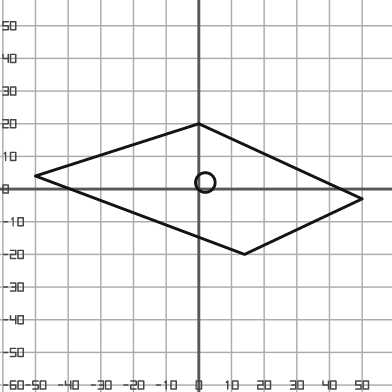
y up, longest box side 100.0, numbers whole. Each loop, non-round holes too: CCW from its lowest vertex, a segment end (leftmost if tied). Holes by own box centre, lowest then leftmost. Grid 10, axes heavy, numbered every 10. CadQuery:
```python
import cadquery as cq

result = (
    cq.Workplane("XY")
    .moveTo(14.0, -20.0)
    .lineTo(50.0, -3.0)
    .lineTo(0.0, 20.0)
    .lineTo(-50.0, 4.0)
    .close()
    .moveTo(2.0, 2.0)
    .circle(3.0)
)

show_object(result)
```